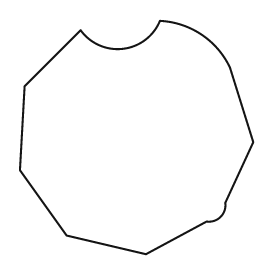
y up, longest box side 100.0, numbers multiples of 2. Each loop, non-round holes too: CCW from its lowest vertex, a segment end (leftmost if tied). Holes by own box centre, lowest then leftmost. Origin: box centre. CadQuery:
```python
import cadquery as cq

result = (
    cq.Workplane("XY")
    .moveTo(4.0, -50.0)
    .lineTo(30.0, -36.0)
    .threePointArc((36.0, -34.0), (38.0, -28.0))
    .lineTo(50.0, -2.0)
    .lineTo(40.0, 30.0)
    .threePointArc((28.0, 44.0), (10.0, 50.0))
    .threePointArc((-6.0, 38.0), (-24.0, 46.0))
    .lineTo(-48.0, 22.0)
    .lineTo(-50.0, -14.0)
    .lineTo(-30.0, -42.0)
    .close()
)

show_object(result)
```